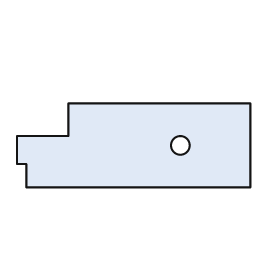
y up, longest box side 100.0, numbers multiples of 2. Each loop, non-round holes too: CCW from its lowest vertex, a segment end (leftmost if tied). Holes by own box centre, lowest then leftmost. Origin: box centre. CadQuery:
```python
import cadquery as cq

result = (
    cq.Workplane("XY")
    .moveTo(-46.0, -18.0)
    .lineTo(50.0, -18.0)
    .lineTo(50.0, 18.0)
    .lineTo(-28.0, 18.0)
    .lineTo(-28.0, 4.0)
    .lineTo(-50.0, 4.0)
    .lineTo(-50.0, -8.0)
    .lineTo(-46.0, -8.0)
    .close()
    .moveTo(20.0, 0.0)
    .circle(4.0)
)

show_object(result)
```